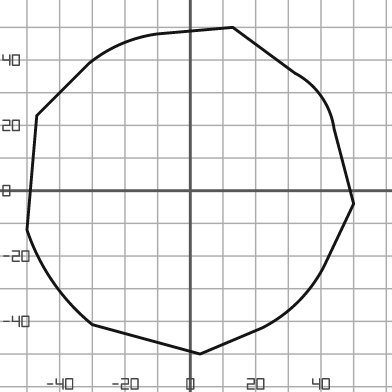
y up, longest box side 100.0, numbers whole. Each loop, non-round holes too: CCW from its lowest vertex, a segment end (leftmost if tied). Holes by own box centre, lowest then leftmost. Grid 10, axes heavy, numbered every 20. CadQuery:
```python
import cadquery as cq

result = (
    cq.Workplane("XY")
    .moveTo(3.0, -50.0)
    .lineTo(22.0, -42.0)
    .threePointArc((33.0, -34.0), (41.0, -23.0))
    .lineTo(50.0, -4.0)
    .lineTo(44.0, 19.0)
    .threePointArc((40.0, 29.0), (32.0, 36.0))
    .lineTo(13.0, 50.0)
    .lineTo(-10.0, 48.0)
    .threePointArc((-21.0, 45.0), (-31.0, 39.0))
    .lineTo(-47.0, 23.0)
    .lineTo(-50.0, -12.0)
    .threePointArc((-42.0, -28.0), (-30.0, -41.0))
    .close()
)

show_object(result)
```